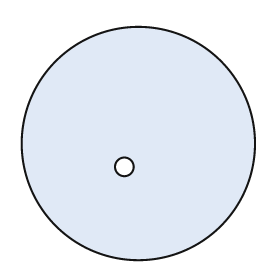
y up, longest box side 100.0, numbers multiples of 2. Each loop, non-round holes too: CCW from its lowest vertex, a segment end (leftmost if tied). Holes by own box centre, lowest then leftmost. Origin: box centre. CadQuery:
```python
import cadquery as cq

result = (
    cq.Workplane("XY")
    .moveTo(0.0, 0.0)
    .circle(50.0)
    .moveTo(-6.0, -10.0)
    .circle(4.0)
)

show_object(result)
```